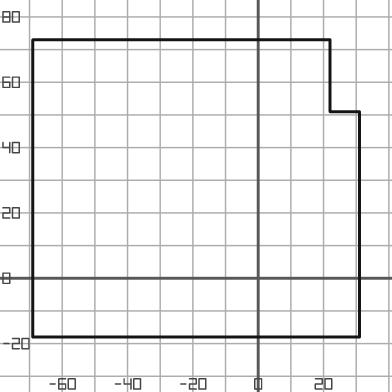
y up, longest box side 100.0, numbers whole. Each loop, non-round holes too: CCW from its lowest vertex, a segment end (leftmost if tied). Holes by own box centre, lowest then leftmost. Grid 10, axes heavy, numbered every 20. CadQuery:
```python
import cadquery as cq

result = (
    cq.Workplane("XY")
    .moveTo(-69.0, -18.0)
    .lineTo(31.0, -18.0)
    .lineTo(31.0, 51.0)
    .lineTo(22.0, 51.0)
    .lineTo(22.0, 73.0)
    .lineTo(-69.0, 73.0)
    .close()
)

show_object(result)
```